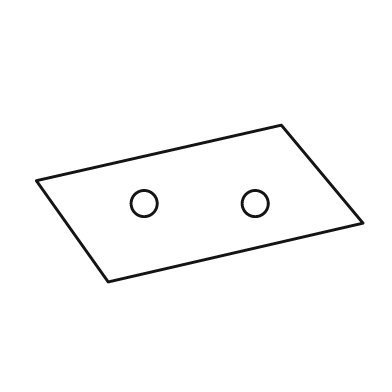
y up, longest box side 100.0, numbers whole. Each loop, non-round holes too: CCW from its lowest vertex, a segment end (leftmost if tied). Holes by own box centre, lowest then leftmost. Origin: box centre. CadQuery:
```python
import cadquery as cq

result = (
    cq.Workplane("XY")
    .moveTo(-28.0, -24.0)
    .lineTo(50.0, -6.0)
    .lineTo(25.0, 24.0)
    .lineTo(-50.0, 7.0)
    .close()
    .moveTo(-17.0, 0.0)
    .circle(4.0)
    .moveTo(17.0, 0.0)
    .circle(4.0)
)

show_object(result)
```